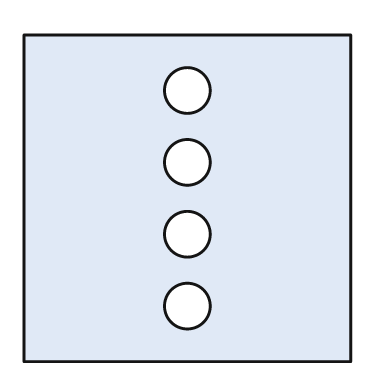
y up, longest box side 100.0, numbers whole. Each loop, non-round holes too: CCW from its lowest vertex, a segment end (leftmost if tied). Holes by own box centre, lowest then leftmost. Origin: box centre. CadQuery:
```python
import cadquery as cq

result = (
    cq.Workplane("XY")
    .moveTo(-50.0, -50.0)
    .lineTo(50.0, -50.0)
    .lineTo(50.0, 50.0)
    .lineTo(-50.0, 50.0)
    .close()
    .moveTo(0.0, -33.0)
    .circle(7.0)
    .moveTo(0.0, -11.0)
    .circle(7.0)
    .moveTo(0.0, 11.0)
    .circle(7.0)
    .moveTo(0.0, 33.0)
    .circle(7.0)
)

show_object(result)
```